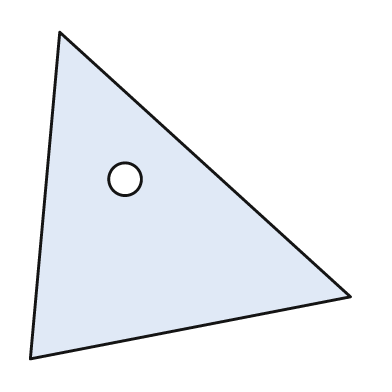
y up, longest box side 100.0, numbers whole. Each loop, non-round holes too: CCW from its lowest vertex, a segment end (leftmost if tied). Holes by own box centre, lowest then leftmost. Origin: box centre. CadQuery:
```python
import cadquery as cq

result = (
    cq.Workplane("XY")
    .moveTo(-49.0, -50.0)
    .lineTo(49.0, -31.0)
    .lineTo(-40.0, 50.0)
    .close()
    .moveTo(-20.0, 5.0)
    .circle(5.0)
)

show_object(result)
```